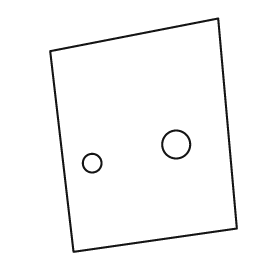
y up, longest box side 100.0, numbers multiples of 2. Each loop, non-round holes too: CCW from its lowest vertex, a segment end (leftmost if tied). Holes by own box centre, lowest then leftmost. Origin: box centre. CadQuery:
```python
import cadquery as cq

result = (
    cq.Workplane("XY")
    .moveTo(-30.0, -50.0)
    .lineTo(40.0, -40.0)
    .lineTo(32.0, 50.0)
    .lineTo(-40.0, 36.0)
    .close()
    .moveTo(-22.0, -12.0)
    .circle(4.0)
    .moveTo(14.0, -4.0)
    .circle(6.0)
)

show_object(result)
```